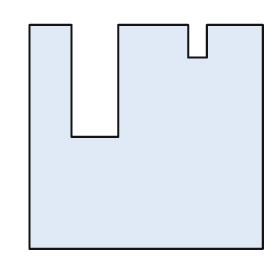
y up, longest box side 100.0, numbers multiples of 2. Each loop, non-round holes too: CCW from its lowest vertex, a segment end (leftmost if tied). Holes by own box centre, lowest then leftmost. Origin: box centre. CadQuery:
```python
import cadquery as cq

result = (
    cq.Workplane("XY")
    .moveTo(-50.0, -48.0)
    .lineTo(50.0, -48.0)
    .lineTo(50.0, 48.0)
    .lineTo(26.0, 48.0)
    .lineTo(26.0, 34.0)
    .lineTo(18.0, 34.0)
    .lineTo(18.0, 48.0)
    .lineTo(-12.0, 48.0)
    .lineTo(-12.0, 0.0)
    .lineTo(-32.0, 0.0)
    .lineTo(-32.0, 48.0)
    .lineTo(-50.0, 48.0)
    .close()
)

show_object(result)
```